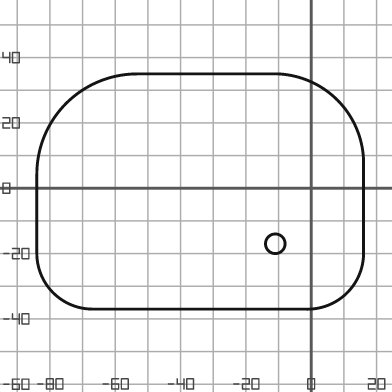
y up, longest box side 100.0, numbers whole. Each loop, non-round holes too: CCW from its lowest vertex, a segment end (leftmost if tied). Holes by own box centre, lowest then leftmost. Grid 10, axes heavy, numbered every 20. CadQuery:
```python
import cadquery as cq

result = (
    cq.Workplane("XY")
    .moveTo(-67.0, -37.0)
    .lineTo(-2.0, -37.0)
    .threePointArc((11.0, -32.0), (16.0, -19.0))
    .lineTo(16.0, 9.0)
    .threePointArc((8.0, 27.0), (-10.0, 35.0))
    .lineTo(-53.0, 35.0)
    .threePointArc((-75.0, 26.0), (-84.0, 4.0))
    .lineTo(-84.0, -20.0)
    .threePointArc((-79.0, -32.0), (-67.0, -37.0))
    .close()
    .moveTo(-11.0, -17.0)
    .circle(3.0)
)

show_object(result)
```